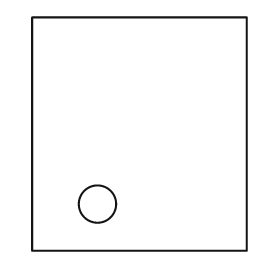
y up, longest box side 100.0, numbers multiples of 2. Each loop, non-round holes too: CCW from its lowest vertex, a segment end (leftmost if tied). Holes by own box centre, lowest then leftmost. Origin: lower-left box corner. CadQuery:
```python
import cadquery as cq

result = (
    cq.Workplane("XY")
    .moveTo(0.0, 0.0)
    .lineTo(92.0, 0.0)
    .lineTo(92.0, 100.0)
    .lineTo(0.0, 100.0)
    .close()
    .moveTo(28.0, 20.0)
    .circle(8.0)
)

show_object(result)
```